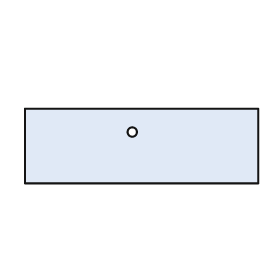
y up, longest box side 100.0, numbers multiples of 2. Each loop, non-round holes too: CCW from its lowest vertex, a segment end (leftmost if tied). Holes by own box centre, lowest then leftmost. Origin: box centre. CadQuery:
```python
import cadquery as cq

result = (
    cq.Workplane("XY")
    .moveTo(-50.0, -16.0)
    .lineTo(50.0, -16.0)
    .lineTo(50.0, 16.0)
    .lineTo(-50.0, 16.0)
    .close()
    .moveTo(-4.0, 6.0)
    .circle(2.0)
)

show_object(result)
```